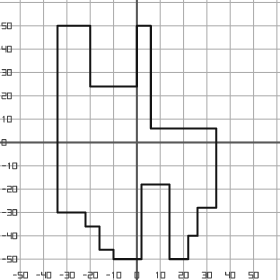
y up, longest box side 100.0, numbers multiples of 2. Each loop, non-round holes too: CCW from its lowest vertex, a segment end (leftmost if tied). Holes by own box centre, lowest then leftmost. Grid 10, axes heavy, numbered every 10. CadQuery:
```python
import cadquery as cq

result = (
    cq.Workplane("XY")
    .moveTo(-10.0, -50.0)
    .lineTo(2.0, -50.0)
    .lineTo(2.0, -18.0)
    .lineTo(14.0, -18.0)
    .lineTo(14.0, -50.0)
    .lineTo(22.0, -50.0)
    .lineTo(22.0, -40.0)
    .lineTo(26.0, -40.0)
    .lineTo(26.0, -28.0)
    .lineTo(34.0, -28.0)
    .lineTo(34.0, 6.0)
    .lineTo(6.0, 6.0)
    .lineTo(6.0, 50.0)
    .lineTo(0.0, 50.0)
    .lineTo(0.0, 24.0)
    .lineTo(-20.0, 24.0)
    .lineTo(-20.0, 50.0)
    .lineTo(-34.0, 50.0)
    .lineTo(-34.0, -30.0)
    .lineTo(-22.0, -30.0)
    .lineTo(-22.0, -36.0)
    .lineTo(-16.0, -36.0)
    .lineTo(-16.0, -46.0)
    .lineTo(-10.0, -46.0)
    .close()
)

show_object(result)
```